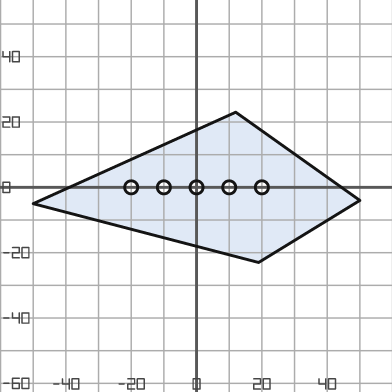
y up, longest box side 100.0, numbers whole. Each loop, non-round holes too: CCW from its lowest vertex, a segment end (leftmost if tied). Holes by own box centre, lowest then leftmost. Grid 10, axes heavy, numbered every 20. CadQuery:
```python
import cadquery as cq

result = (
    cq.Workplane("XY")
    .moveTo(19.0, -23.0)
    .lineTo(50.0, -4.0)
    .lineTo(12.0, 23.0)
    .lineTo(-50.0, -5.0)
    .close()
    .moveTo(-20.0, 0.0)
    .circle(2.0)
    .moveTo(-10.0, 0.0)
    .circle(2.0)
    .moveTo(0.0, 0.0)
    .circle(2.0)
    .moveTo(10.0, 0.0)
    .circle(2.0)
    .moveTo(20.0, 0.0)
    .circle(2.0)
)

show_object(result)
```